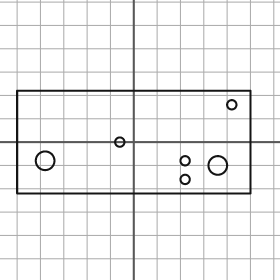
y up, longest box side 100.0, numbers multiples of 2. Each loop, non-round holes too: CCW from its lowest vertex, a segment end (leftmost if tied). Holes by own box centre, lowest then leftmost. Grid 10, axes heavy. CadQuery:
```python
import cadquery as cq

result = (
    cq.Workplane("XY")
    .moveTo(-50.0, -22.0)
    .lineTo(50.0, -22.0)
    .lineTo(50.0, 22.0)
    .lineTo(-50.0, 22.0)
    .close()
    .moveTo(22.0, -16.0)
    .circle(2.0)
    .moveTo(36.0, -10.0)
    .circle(4.0)
    .moveTo(-38.0, -8.0)
    .circle(4.0)
    .moveTo(22.0, -8.0)
    .circle(2.0)
    .moveTo(-6.0, 0.0)
    .circle(2.0)
    .moveTo(42.0, 16.0)
    .circle(2.0)
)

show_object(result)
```